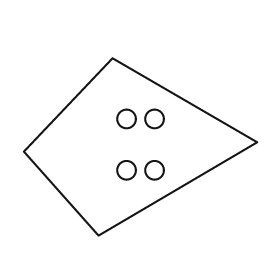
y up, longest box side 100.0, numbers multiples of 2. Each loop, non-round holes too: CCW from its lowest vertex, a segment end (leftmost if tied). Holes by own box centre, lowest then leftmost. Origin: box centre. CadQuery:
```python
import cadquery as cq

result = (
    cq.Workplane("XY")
    .moveTo(-18.0, -38.0)
    .lineTo(50.0, 2.0)
    .lineTo(-12.0, 38.0)
    .lineTo(-50.0, -2.0)
    .close()
    .moveTo(-6.0, -10.0)
    .circle(4.0)
    .moveTo(6.0, -10.0)
    .circle(4.0)
    .moveTo(-6.0, 12.0)
    .circle(4.0)
    .moveTo(6.0, 12.0)
    .circle(4.0)
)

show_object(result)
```